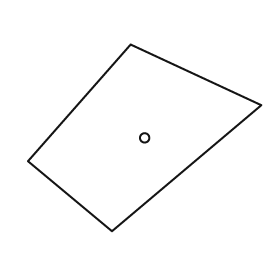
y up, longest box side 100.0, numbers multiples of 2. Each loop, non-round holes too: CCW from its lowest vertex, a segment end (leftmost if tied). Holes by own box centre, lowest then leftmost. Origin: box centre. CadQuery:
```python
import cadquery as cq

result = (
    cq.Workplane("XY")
    .moveTo(-14.0, -40.0)
    .lineTo(50.0, 14.0)
    .lineTo(-6.0, 40.0)
    .lineTo(-50.0, -10.0)
    .close()
    .moveTo(0.0, 0.0)
    .circle(2.0)
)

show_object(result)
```